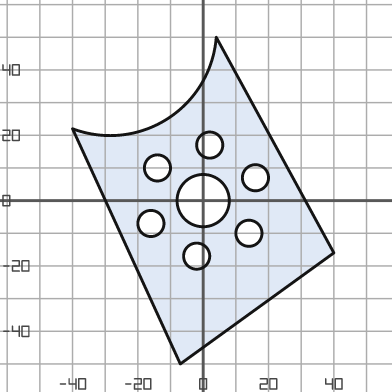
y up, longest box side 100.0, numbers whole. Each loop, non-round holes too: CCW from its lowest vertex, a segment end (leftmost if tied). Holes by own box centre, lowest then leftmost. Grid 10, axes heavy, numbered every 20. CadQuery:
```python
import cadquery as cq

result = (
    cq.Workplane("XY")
    .moveTo(-7.0, -50.0)
    .lineTo(40.0, -16.0)
    .lineTo(4.0, 50.0)
    .threePointArc((-11.0, 25.0), (-40.0, 22.0))
    .close()
    .moveTo(-2.0, -17.0)
    .circle(4.0)
    .moveTo(14.0, -10.0)
    .circle(4.0)
    .moveTo(-16.0, -7.0)
    .circle(4.0)
    .moveTo(0.0, 0.0)
    .circle(8.0)
    .moveTo(16.0, 7.0)
    .circle(4.0)
    .moveTo(-14.0, 10.0)
    .circle(4.0)
    .moveTo(2.0, 17.0)
    .circle(4.0)
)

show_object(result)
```